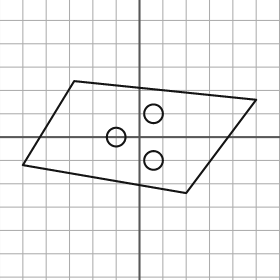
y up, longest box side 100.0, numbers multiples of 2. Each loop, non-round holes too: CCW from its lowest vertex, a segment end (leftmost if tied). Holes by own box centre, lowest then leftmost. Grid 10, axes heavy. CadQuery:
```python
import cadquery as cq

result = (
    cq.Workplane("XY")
    .moveTo(20.0, -24.0)
    .lineTo(50.0, 16.0)
    .lineTo(-28.0, 24.0)
    .lineTo(-50.0, -12.0)
    .close()
    .moveTo(6.0, -10.0)
    .circle(4.0)
    .moveTo(-10.0, 0.0)
    .circle(4.0)
    .moveTo(6.0, 10.0)
    .circle(4.0)
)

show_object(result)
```